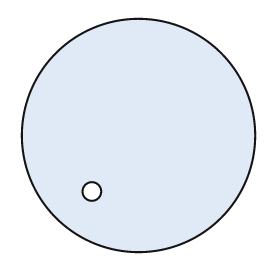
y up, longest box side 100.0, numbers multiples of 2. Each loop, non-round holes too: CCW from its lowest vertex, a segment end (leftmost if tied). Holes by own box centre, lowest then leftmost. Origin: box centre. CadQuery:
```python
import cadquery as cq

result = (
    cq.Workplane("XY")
    .moveTo(0.0, 0.0)
    .circle(50.0)
    .moveTo(-20.0, -24.0)
    .circle(4.0)
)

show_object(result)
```